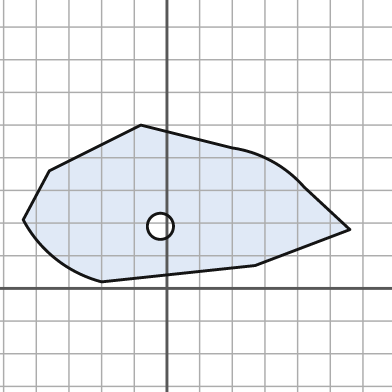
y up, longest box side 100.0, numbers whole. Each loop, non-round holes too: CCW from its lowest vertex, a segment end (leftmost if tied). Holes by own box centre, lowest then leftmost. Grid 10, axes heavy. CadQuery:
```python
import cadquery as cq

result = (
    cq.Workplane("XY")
    .moveTo(-20.0, 2.0)
    .lineTo(27.0, 7.0)
    .lineTo(56.0, 18.0)
    .lineTo(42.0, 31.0)
    .threePointArc((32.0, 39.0), (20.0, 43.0))
    .lineTo(-8.0, 50.0)
    .lineTo(-36.0, 36.0)
    .lineTo(-44.0, 21.0)
    .threePointArc((-34.0, 9.0), (-20.0, 2.0))
    .close()
    .moveTo(-2.0, 19.0)
    .circle(4.0)
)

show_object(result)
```